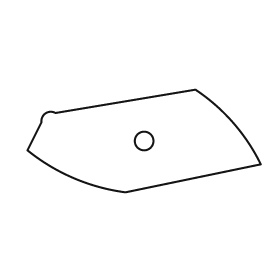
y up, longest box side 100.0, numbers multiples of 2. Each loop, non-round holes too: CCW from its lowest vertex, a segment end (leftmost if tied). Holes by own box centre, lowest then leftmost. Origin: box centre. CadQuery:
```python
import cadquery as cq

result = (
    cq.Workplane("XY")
    .moveTo(-8.0, -22.0)
    .lineTo(50.0, -10.0)
    .threePointArc((38.0, 8.0), (22.0, 22.0))
    .lineTo(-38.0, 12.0)
    .threePointArc((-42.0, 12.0), (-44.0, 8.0))
    .lineTo(-50.0, -4.0)
    .threePointArc((-30.0, -16.0), (-8.0, -22.0))
    .close()
    .moveTo(0.0, 0.0)
    .circle(4.0)
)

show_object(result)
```